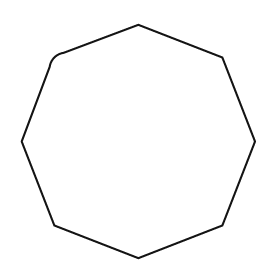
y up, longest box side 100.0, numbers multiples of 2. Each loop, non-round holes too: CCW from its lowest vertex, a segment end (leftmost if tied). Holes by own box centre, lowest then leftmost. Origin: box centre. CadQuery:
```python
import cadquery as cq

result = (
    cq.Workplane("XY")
    .moveTo(0.0, -50.0)
    .lineTo(36.0, -36.0)
    .lineTo(50.0, 0.0)
    .lineTo(36.0, 36.0)
    .lineTo(0.0, 50.0)
    .lineTo(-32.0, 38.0)
    .threePointArc((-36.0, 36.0), (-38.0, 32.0))
    .lineTo(-50.0, 0.0)
    .lineTo(-36.0, -36.0)
    .close()
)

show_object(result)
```